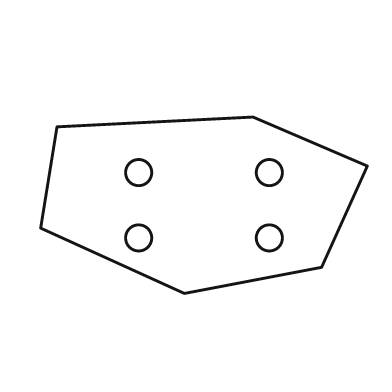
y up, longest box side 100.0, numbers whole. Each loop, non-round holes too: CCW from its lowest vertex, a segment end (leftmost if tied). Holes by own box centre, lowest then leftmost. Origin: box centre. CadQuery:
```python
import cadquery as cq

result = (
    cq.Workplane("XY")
    .moveTo(-6.0, -27.0)
    .lineTo(36.0, -19.0)
    .lineTo(50.0, 12.0)
    .lineTo(15.0, 27.0)
    .lineTo(-45.0, 24.0)
    .lineTo(-50.0, -7.0)
    .close()
    .moveTo(-20.0, -10.0)
    .circle(4.0)
    .moveTo(20.0, -10.0)
    .circle(4.0)
    .moveTo(-20.0, 10.0)
    .circle(4.0)
    .moveTo(20.0, 10.0)
    .circle(4.0)
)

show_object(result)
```